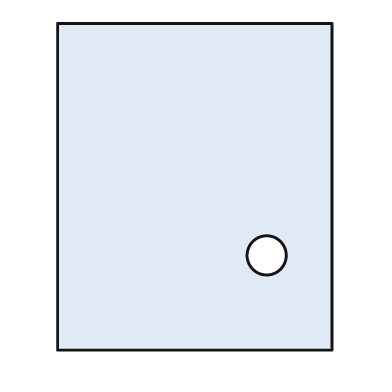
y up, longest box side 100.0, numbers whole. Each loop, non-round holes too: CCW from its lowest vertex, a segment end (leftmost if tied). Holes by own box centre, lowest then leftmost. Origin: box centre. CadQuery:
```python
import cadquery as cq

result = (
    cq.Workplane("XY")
    .moveTo(-42.0, -50.0)
    .lineTo(42.0, -50.0)
    .lineTo(42.0, 50.0)
    .lineTo(-42.0, 50.0)
    .close()
    .moveTo(22.0, -21.0)
    .circle(6.0)
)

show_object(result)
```